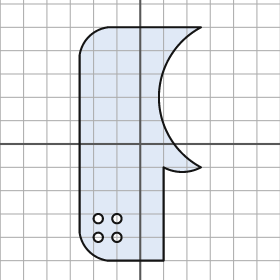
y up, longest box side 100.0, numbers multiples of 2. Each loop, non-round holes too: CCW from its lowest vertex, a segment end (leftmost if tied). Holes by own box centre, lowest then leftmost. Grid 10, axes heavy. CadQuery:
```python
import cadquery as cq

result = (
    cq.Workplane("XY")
    .moveTo(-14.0, -50.0)
    .lineTo(10.0, -50.0)
    .lineTo(10.0, -10.0)
    .threePointArc((18.0, -12.0), (26.0, -10.0))
    .threePointArc((8.0, 20.0), (26.0, 50.0))
    .lineTo(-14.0, 50.0)
    .threePointArc((-22.0, 46.0), (-26.0, 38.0))
    .lineTo(-26.0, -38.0)
    .threePointArc((-22.0, -46.0), (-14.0, -50.0))
    .close()
    .moveTo(-18.0, -40.0)
    .circle(2.0)
    .moveTo(-10.0, -40.0)
    .circle(2.0)
    .moveTo(-18.0, -32.0)
    .circle(2.0)
    .moveTo(-10.0, -32.0)
    .circle(2.0)
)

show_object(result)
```